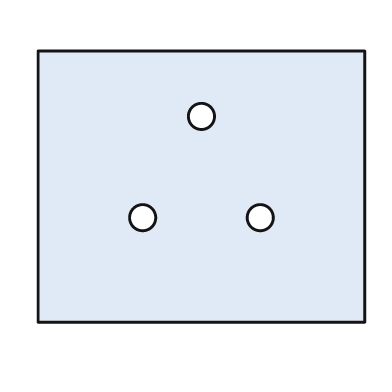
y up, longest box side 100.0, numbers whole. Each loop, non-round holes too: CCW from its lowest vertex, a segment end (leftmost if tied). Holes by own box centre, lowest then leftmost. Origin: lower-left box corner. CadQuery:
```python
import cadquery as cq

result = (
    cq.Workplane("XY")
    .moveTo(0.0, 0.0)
    .lineTo(100.0, 0.0)
    .lineTo(100.0, 83.0)
    .lineTo(0.0, 83.0)
    .close()
    .moveTo(32.0, 32.0)
    .circle(4.0)
    .moveTo(68.0, 32.0)
    .circle(4.0)
    .moveTo(50.0, 63.0)
    .circle(4.0)
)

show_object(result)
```